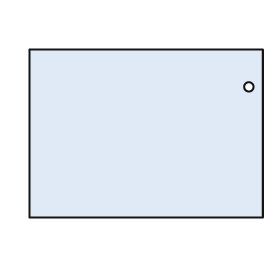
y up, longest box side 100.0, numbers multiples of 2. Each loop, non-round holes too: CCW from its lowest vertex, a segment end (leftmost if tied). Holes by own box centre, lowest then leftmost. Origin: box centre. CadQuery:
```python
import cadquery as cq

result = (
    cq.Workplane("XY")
    .moveTo(-50.0, -36.0)
    .lineTo(50.0, -36.0)
    .lineTo(50.0, 36.0)
    .lineTo(-50.0, 36.0)
    .close()
    .moveTo(44.0, 20.0)
    .circle(2.0)
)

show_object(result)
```